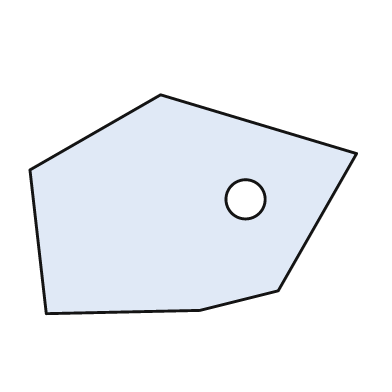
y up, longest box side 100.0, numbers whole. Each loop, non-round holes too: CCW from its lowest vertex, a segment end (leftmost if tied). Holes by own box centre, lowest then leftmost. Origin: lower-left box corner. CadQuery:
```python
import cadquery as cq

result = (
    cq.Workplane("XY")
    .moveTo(5.0, 0.0)
    .lineTo(52.0, 1.0)
    .lineTo(76.0, 7.0)
    .lineTo(100.0, 49.0)
    .lineTo(40.0, 67.0)
    .lineTo(0.0, 44.0)
    .close()
    .moveTo(66.0, 35.0)
    .circle(6.0)
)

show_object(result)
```